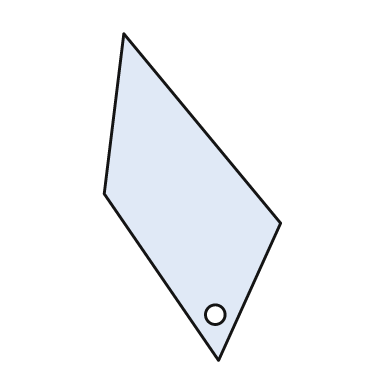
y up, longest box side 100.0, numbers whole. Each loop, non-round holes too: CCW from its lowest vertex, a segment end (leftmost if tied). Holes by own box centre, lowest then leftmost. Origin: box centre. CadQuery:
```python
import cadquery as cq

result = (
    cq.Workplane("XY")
    .moveTo(8.0, -50.0)
    .lineTo(27.0, -8.0)
    .lineTo(-21.0, 50.0)
    .lineTo(-27.0, 1.0)
    .close()
    .moveTo(7.0, -36.0)
    .circle(3.0)
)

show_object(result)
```